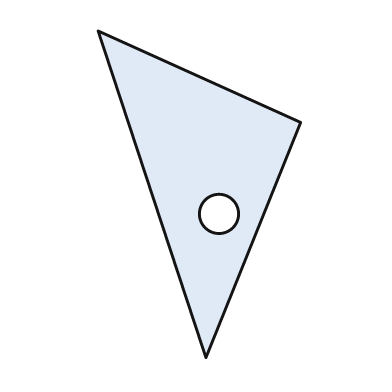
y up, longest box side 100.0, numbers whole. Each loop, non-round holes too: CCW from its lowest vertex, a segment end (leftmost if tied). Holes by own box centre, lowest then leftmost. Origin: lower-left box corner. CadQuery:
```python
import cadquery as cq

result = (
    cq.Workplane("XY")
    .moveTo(33.0, 0.0)
    .lineTo(62.0, 72.0)
    .lineTo(0.0, 100.0)
    .close()
    .moveTo(37.0, 44.0)
    .circle(6.0)
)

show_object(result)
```